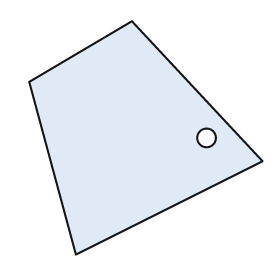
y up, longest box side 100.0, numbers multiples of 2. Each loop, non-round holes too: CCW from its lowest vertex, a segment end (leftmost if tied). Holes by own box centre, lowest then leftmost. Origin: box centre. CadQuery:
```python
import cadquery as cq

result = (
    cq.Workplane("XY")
    .moveTo(-30.0, -50.0)
    .lineTo(50.0, -10.0)
    .lineTo(-6.0, 50.0)
    .lineTo(-50.0, 24.0)
    .close()
    .moveTo(26.0, 0.0)
    .circle(4.0)
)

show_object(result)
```